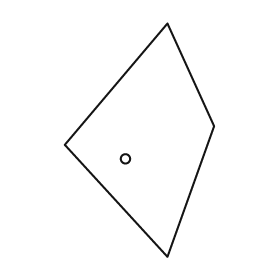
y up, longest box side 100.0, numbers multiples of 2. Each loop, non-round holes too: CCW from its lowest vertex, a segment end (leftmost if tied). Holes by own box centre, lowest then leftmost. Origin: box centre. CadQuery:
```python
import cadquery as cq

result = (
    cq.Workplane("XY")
    .moveTo(12.0, -50.0)
    .lineTo(32.0, 6.0)
    .lineTo(12.0, 50.0)
    .lineTo(-32.0, -2.0)
    .close()
    .moveTo(-6.0, -8.0)
    .circle(2.0)
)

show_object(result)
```